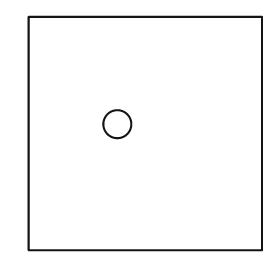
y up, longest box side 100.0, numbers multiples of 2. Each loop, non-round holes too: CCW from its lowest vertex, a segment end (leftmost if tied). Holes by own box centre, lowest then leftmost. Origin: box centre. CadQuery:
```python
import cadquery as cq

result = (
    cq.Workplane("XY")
    .moveTo(-50.0, -50.0)
    .lineTo(50.0, -50.0)
    .lineTo(50.0, 50.0)
    .lineTo(-50.0, 50.0)
    .close()
    .moveTo(-12.0, 4.0)
    .circle(6.0)
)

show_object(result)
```